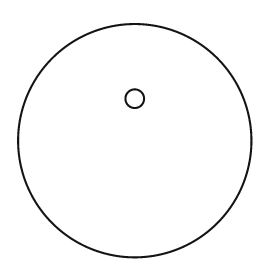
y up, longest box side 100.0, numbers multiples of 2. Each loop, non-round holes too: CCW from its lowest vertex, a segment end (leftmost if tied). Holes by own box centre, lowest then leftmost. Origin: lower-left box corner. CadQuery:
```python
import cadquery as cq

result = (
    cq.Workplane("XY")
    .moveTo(50.0, 50.0)
    .circle(50.0)
    .moveTo(50.0, 68.0)
    .circle(4.0)
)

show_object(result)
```